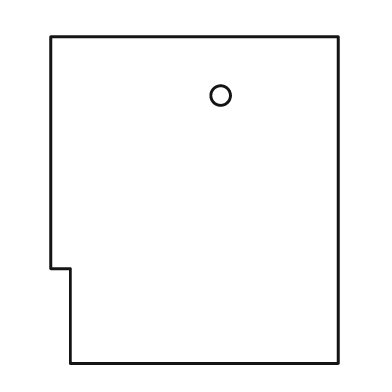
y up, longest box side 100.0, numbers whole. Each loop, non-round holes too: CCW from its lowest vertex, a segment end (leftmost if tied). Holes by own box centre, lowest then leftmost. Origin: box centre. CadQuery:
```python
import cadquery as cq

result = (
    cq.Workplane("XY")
    .moveTo(-38.0, -50.0)
    .lineTo(44.0, -50.0)
    .lineTo(44.0, 50.0)
    .lineTo(-44.0, 50.0)
    .lineTo(-44.0, -21.0)
    .lineTo(-38.0, -21.0)
    .close()
    .moveTo(8.0, 32.0)
    .circle(3.0)
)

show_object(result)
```